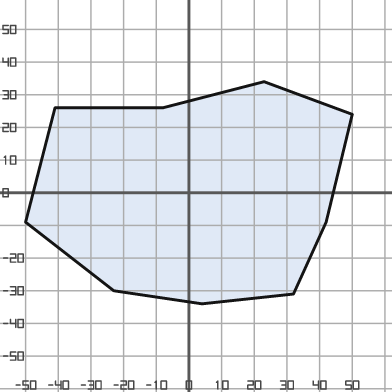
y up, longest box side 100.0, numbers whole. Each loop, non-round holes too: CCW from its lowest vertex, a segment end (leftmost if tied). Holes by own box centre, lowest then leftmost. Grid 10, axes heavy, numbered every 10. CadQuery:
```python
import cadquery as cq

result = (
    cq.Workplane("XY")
    .moveTo(4.0, -34.0)
    .lineTo(32.0, -31.0)
    .lineTo(42.0, -9.0)
    .lineTo(50.0, 24.0)
    .lineTo(23.0, 34.0)
    .lineTo(-8.0, 26.0)
    .lineTo(-41.0, 26.0)
    .lineTo(-50.0, -9.0)
    .lineTo(-23.0, -30.0)
    .close()
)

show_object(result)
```